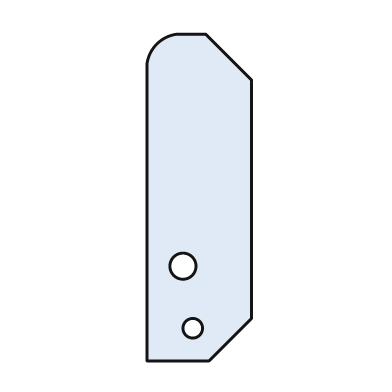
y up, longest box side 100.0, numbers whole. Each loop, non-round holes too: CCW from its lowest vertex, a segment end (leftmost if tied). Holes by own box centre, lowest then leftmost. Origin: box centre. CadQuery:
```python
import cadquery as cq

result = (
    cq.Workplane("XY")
    .moveTo(-16.0, -50.0)
    .lineTo(3.0, -50.0)
    .lineTo(16.0, -37.0)
    .lineTo(16.0, 36.0)
    .lineTo(2.0, 50.0)
    .lineTo(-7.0, 50.0)
    .threePointArc((-13.0, 47.0), (-16.0, 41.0))
    .close()
    .moveTo(-2.0, -40.0)
    .circle(3.0)
    .moveTo(-5.0, -21.0)
    .circle(4.0)
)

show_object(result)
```